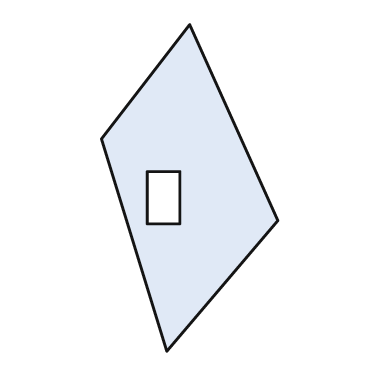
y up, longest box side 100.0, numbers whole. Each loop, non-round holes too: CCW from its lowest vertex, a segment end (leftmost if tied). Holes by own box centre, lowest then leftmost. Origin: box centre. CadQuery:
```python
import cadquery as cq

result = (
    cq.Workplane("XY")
    .moveTo(-7.0, -50.0)
    .lineTo(27.0, -10.0)
    .lineTo(0.0, 50.0)
    .lineTo(-27.0, 15.0)
    .close()
    .moveTo(-13.0, -11.0)
    .lineTo(-3.0, -11.0)
    .lineTo(-3.0, 5.0)
    .lineTo(-13.0, 5.0)
    .close()
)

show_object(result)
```